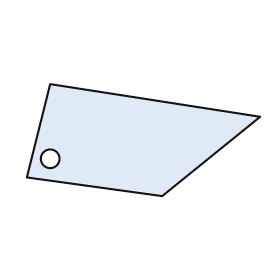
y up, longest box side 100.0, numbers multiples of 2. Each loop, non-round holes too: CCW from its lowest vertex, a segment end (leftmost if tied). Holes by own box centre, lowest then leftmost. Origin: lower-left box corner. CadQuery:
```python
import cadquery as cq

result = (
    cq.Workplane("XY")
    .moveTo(58.0, 0.0)
    .lineTo(100.0, 34.0)
    .lineTo(10.0, 48.0)
    .lineTo(0.0, 8.0)
    .close()
    .moveTo(10.0, 16.0)
    .circle(4.0)
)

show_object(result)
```